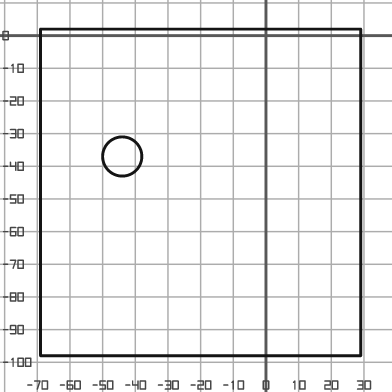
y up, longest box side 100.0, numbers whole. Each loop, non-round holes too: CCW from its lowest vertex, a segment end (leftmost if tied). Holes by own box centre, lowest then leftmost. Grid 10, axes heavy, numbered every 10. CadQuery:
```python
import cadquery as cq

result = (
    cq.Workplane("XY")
    .moveTo(-69.0, -98.0)
    .lineTo(29.0, -98.0)
    .lineTo(29.0, 2.0)
    .lineTo(-69.0, 2.0)
    .close()
    .moveTo(-44.0, -37.0)
    .circle(6.0)
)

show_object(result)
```